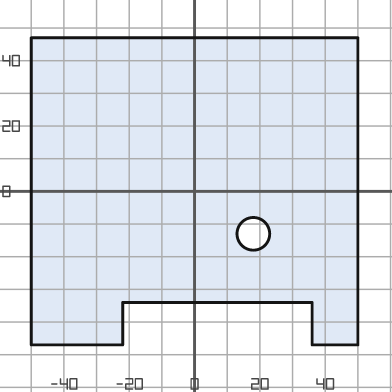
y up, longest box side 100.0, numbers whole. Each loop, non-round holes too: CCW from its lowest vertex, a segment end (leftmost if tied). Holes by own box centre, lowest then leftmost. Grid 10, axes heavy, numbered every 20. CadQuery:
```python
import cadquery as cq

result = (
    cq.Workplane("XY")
    .moveTo(-50.0, -47.0)
    .lineTo(-22.0, -47.0)
    .lineTo(-22.0, -34.0)
    .lineTo(36.0, -34.0)
    .lineTo(36.0, -47.0)
    .lineTo(50.0, -47.0)
    .lineTo(50.0, 47.0)
    .lineTo(-50.0, 47.0)
    .close()
    .moveTo(18.0, -13.0)
    .circle(5.0)
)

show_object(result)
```